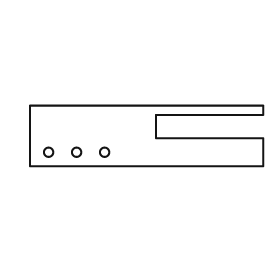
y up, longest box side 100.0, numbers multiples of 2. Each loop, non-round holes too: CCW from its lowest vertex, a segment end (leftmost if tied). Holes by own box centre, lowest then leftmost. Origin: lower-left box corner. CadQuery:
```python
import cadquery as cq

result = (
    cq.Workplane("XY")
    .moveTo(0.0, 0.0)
    .lineTo(100.0, 0.0)
    .lineTo(100.0, 12.0)
    .lineTo(54.0, 12.0)
    .lineTo(54.0, 22.0)
    .lineTo(100.0, 22.0)
    .lineTo(100.0, 26.0)
    .lineTo(0.0, 26.0)
    .close()
    .moveTo(8.0, 6.0)
    .circle(2.0)
    .moveTo(20.0, 6.0)
    .circle(2.0)
    .moveTo(32.0, 6.0)
    .circle(2.0)
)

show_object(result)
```